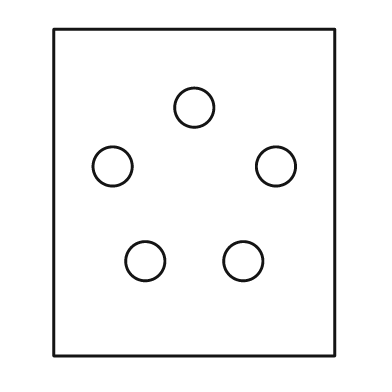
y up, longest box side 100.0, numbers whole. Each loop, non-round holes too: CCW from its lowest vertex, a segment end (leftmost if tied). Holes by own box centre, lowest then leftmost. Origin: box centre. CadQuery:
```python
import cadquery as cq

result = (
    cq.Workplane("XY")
    .moveTo(-43.0, -50.0)
    .lineTo(43.0, -50.0)
    .lineTo(43.0, 50.0)
    .lineTo(-43.0, 50.0)
    .close()
    .moveTo(-15.0, -21.0)
    .circle(6.0)
    .moveTo(15.0, -21.0)
    .circle(6.0)
    .moveTo(-25.0, 8.0)
    .circle(6.0)
    .moveTo(25.0, 8.0)
    .circle(6.0)
    .moveTo(0.0, 26.0)
    .circle(6.0)
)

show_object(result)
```